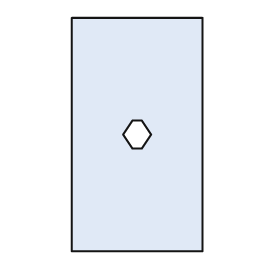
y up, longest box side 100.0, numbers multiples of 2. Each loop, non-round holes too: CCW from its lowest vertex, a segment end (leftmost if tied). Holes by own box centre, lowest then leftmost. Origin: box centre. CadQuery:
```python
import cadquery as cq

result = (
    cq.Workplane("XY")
    .moveTo(-28.0, -50.0)
    .lineTo(28.0, -50.0)
    .lineTo(28.0, 50.0)
    .lineTo(-28.0, 50.0)
    .close()
    .moveTo(-2.0, -6.0)
    .lineTo(2.0, -6.0)
    .lineTo(6.0, 0.0)
    .lineTo(2.0, 6.0)
    .lineTo(-2.0, 6.0)
    .lineTo(-6.0, 0.0)
    .close()
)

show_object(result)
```